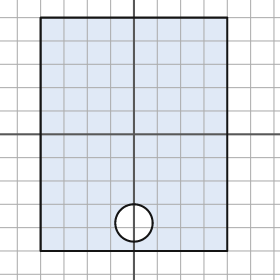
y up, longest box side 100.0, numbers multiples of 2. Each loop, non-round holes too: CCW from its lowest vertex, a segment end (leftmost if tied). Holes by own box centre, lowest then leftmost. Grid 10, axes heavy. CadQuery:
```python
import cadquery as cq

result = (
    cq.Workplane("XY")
    .moveTo(-40.0, -50.0)
    .lineTo(40.0, -50.0)
    .lineTo(40.0, 50.0)
    .lineTo(-40.0, 50.0)
    .close()
    .moveTo(0.0, -38.0)
    .circle(8.0)
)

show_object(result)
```